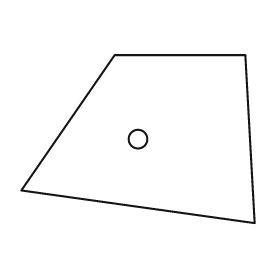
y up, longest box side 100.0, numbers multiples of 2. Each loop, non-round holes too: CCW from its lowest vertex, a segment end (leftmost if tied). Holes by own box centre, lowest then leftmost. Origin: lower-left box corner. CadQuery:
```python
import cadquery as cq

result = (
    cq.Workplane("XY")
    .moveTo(100.0, 0.0)
    .lineTo(96.0, 72.0)
    .lineTo(40.0, 72.0)
    .lineTo(0.0, 14.0)
    .close()
    .moveTo(50.0, 36.0)
    .circle(4.0)
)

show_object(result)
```